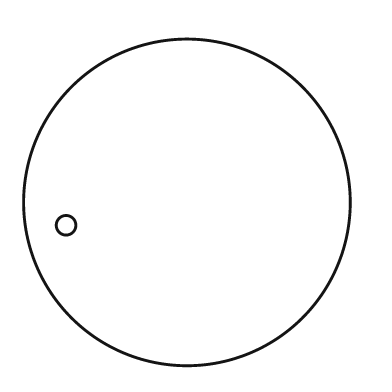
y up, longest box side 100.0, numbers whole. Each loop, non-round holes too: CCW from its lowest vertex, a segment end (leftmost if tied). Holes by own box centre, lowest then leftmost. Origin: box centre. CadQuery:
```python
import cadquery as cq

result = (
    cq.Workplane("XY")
    .moveTo(0.0, 0.0)
    .circle(50.0)
    .moveTo(-37.0, -7.0)
    .circle(3.0)
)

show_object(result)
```